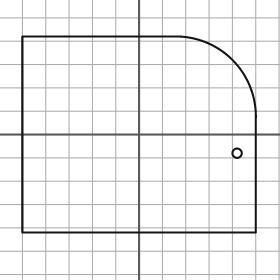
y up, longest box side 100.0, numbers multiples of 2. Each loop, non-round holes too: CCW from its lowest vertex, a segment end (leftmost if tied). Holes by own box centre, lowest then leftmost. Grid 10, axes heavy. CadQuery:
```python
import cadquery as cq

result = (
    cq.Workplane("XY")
    .moveTo(-50.0, -42.0)
    .lineTo(50.0, -42.0)
    .lineTo(50.0, 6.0)
    .threePointArc((40.0, 32.0), (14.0, 42.0))
    .lineTo(-50.0, 42.0)
    .close()
    .moveTo(42.0, -8.0)
    .circle(2.0)
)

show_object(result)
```